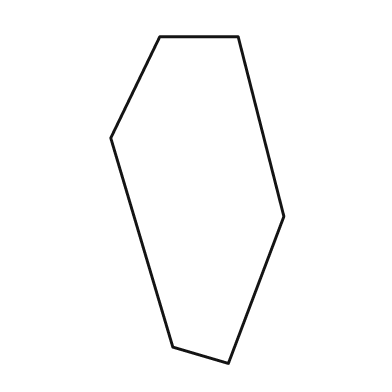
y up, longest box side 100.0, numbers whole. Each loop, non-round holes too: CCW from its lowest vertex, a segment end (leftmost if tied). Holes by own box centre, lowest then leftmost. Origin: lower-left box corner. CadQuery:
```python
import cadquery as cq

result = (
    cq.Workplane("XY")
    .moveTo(36.0, 0.0)
    .lineTo(53.0, 45.0)
    .lineTo(39.0, 100.0)
    .lineTo(15.0, 100.0)
    .lineTo(0.0, 69.0)
    .lineTo(19.0, 5.0)
    .close()
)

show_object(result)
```